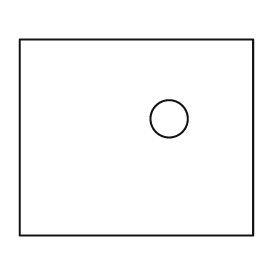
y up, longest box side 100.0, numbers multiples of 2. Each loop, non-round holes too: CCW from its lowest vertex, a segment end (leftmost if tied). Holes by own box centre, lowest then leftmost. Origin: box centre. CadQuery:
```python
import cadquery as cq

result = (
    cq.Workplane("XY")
    .moveTo(-50.0, -42.0)
    .lineTo(50.0, -42.0)
    .lineTo(50.0, 42.0)
    .lineTo(-50.0, 42.0)
    .close()
    .moveTo(14.0, 8.0)
    .circle(8.0)
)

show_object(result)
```